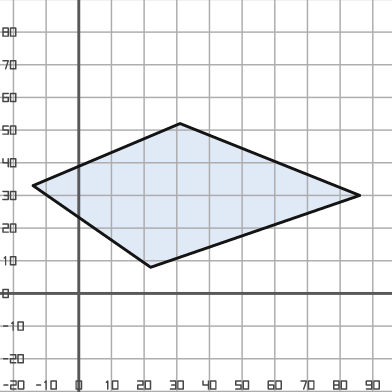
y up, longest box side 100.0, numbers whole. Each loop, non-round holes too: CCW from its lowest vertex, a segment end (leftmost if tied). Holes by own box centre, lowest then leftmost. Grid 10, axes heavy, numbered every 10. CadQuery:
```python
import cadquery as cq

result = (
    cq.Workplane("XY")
    .moveTo(22.0, 8.0)
    .lineTo(86.0, 30.0)
    .lineTo(31.0, 52.0)
    .lineTo(-14.0, 33.0)
    .close()
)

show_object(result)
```